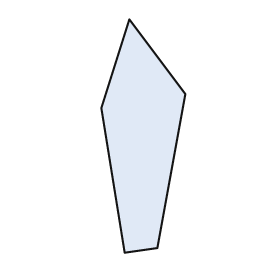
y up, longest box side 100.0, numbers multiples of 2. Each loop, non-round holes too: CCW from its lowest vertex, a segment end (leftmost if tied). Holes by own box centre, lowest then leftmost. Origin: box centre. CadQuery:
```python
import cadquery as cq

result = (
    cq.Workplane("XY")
    .moveTo(-8.0, -50.0)
    .lineTo(6.0, -48.0)
    .lineTo(18.0, 18.0)
    .lineTo(-6.0, 50.0)
    .lineTo(-18.0, 12.0)
    .close()
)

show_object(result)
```